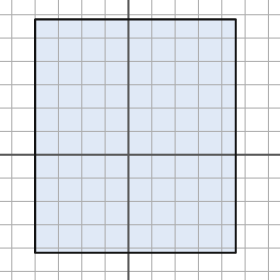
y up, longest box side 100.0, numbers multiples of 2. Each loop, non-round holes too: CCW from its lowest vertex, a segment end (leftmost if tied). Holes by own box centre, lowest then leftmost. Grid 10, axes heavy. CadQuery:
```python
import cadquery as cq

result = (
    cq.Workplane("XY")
    .moveTo(-40.0, -42.0)
    .lineTo(46.0, -42.0)
    .lineTo(46.0, 58.0)
    .lineTo(-40.0, 58.0)
    .close()
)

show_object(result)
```